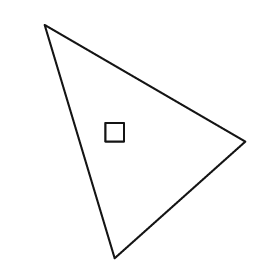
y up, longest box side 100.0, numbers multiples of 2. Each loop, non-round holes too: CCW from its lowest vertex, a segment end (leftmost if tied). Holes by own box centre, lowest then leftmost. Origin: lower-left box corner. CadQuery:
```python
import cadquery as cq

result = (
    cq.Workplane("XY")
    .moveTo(30.0, 0.0)
    .lineTo(86.0, 50.0)
    .lineTo(0.0, 100.0)
    .close()
    .moveTo(26.0, 50.0)
    .lineTo(34.0, 50.0)
    .lineTo(34.0, 58.0)
    .lineTo(26.0, 58.0)
    .close()
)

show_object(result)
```